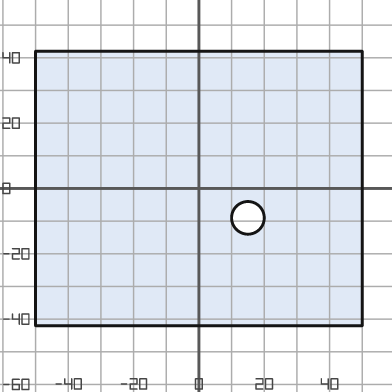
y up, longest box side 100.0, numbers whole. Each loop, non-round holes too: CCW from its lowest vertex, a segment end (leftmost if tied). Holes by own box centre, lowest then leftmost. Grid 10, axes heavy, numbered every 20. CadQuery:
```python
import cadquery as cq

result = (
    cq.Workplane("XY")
    .moveTo(-50.0, -42.0)
    .lineTo(50.0, -42.0)
    .lineTo(50.0, 42.0)
    .lineTo(-50.0, 42.0)
    .close()
    .moveTo(15.0, -9.0)
    .circle(5.0)
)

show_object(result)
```